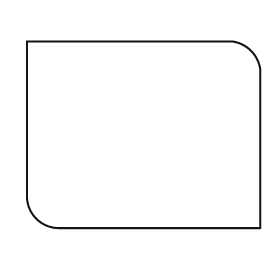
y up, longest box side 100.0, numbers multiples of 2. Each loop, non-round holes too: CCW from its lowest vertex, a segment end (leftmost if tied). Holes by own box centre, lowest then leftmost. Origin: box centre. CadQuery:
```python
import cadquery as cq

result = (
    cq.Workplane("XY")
    .moveTo(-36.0, -40.0)
    .lineTo(50.0, -40.0)
    .lineTo(50.0, 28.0)
    .threePointArc((46.0, 36.0), (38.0, 40.0))
    .lineTo(-50.0, 40.0)
    .lineTo(-50.0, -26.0)
    .threePointArc((-46.0, -36.0), (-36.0, -40.0))
    .close()
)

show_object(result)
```